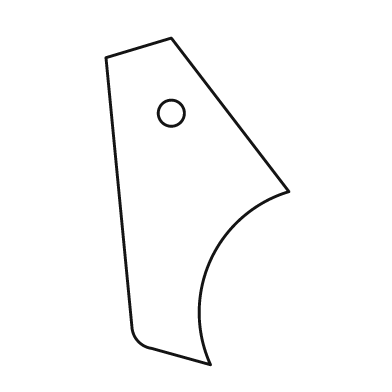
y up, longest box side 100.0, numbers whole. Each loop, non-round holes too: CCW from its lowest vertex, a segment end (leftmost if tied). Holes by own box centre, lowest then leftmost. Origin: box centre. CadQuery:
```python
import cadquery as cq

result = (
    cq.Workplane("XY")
    .moveTo(4.0, -50.0)
    .threePointArc((4.0, -18.0), (28.0, 3.0))
    .lineTo(-8.0, 50.0)
    .lineTo(-28.0, 44.0)
    .lineTo(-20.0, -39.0)
    .threePointArc((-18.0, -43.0), (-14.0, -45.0))
    .close()
    .moveTo(-8.0, 27.0)
    .circle(4.0)
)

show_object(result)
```